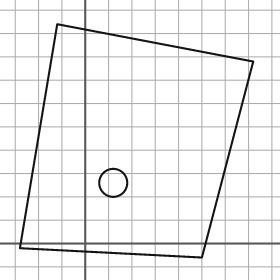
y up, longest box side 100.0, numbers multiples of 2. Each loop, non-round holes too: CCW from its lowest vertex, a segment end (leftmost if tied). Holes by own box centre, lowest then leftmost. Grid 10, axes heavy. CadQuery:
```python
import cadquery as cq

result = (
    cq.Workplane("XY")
    .moveTo(50.0, -6.0)
    .lineTo(72.0, 78.0)
    .lineTo(-12.0, 94.0)
    .lineTo(-28.0, -2.0)
    .close()
    .moveTo(12.0, 26.0)
    .circle(6.0)
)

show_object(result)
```